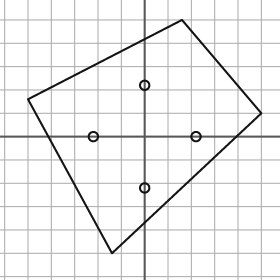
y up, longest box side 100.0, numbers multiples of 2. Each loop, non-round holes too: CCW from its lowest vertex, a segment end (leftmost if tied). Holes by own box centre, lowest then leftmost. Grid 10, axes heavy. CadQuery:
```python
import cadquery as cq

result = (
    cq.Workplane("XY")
    .moveTo(-14.0, -50.0)
    .lineTo(50.0, 10.0)
    .lineTo(16.0, 50.0)
    .lineTo(-50.0, 16.0)
    .close()
    .moveTo(0.0, -22.0)
    .circle(2.0)
    .moveTo(-22.0, 0.0)
    .circle(2.0)
    .moveTo(22.0, 0.0)
    .circle(2.0)
    .moveTo(0.0, 22.0)
    .circle(2.0)
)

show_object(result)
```